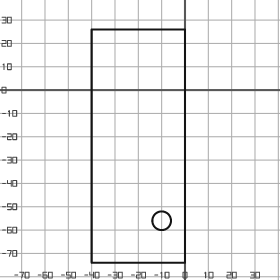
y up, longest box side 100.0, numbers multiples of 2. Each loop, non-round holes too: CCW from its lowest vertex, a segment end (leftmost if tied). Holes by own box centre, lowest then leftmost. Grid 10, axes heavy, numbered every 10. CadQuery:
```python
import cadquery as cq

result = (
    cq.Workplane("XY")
    .moveTo(-40.0, -74.0)
    .lineTo(0.0, -74.0)
    .lineTo(0.0, 26.0)
    .lineTo(-40.0, 26.0)
    .close()
    .moveTo(-10.0, -56.0)
    .circle(4.0)
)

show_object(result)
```